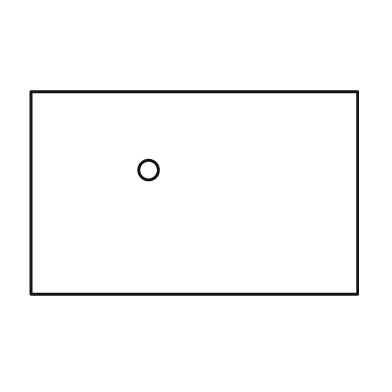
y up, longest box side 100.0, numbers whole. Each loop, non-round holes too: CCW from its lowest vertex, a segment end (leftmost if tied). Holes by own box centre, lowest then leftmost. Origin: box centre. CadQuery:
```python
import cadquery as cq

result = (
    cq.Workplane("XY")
    .moveTo(-50.0, -31.0)
    .lineTo(50.0, -31.0)
    .lineTo(50.0, 31.0)
    .lineTo(-50.0, 31.0)
    .close()
    .moveTo(-14.0, 7.0)
    .circle(3.0)
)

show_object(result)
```